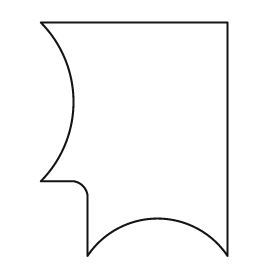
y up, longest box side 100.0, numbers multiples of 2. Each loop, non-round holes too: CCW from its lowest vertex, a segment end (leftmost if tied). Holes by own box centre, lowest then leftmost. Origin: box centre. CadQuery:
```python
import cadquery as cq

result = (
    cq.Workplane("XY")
    .moveTo(-20.0, -50.0)
    .threePointArc((10.0, -34.0), (40.0, -50.0))
    .lineTo(40.0, 50.0)
    .lineTo(-40.0, 50.0)
    .threePointArc((-26.0, 16.0), (-40.0, -18.0))
    .lineTo(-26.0, -18.0)
    .threePointArc((-22.0, -20.0), (-20.0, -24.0))
    .close()
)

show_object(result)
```